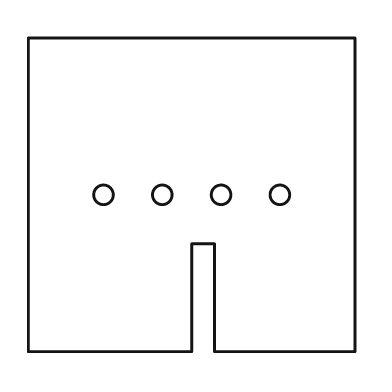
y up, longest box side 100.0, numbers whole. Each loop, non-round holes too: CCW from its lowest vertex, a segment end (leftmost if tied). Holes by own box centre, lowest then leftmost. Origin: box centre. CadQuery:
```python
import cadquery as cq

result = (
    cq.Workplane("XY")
    .moveTo(-50.0, -48.0)
    .lineTo(0.0, -48.0)
    .lineTo(0.0, -15.0)
    .lineTo(7.0, -15.0)
    .lineTo(7.0, -48.0)
    .lineTo(50.0, -48.0)
    .lineTo(50.0, 48.0)
    .lineTo(-50.0, 48.0)
    .close()
    .moveTo(-27.0, 0.0)
    .circle(3.0)
    .moveTo(-9.0, 0.0)
    .circle(3.0)
    .moveTo(9.0, 0.0)
    .circle(3.0)
    .moveTo(27.0, 0.0)
    .circle(3.0)
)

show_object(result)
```